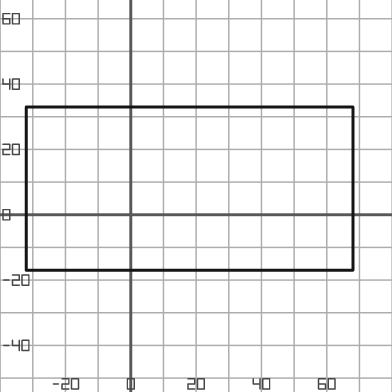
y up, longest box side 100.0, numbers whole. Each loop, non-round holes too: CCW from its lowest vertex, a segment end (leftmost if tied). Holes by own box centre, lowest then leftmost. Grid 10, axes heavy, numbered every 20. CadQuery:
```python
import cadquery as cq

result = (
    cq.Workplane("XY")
    .moveTo(-32.0, -17.0)
    .lineTo(68.0, -17.0)
    .lineTo(68.0, 33.0)
    .lineTo(-32.0, 33.0)
    .close()
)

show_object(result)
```